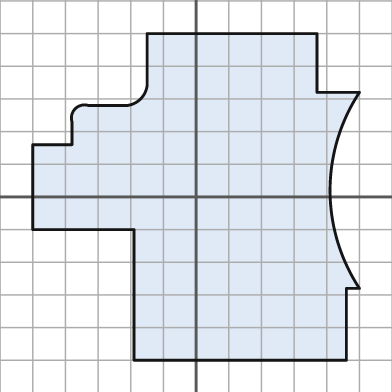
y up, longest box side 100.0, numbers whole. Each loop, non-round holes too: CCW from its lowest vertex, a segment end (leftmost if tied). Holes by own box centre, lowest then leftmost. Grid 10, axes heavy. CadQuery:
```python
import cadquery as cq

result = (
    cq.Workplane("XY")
    .moveTo(-19.0, -50.0)
    .lineTo(46.0, -50.0)
    .lineTo(46.0, -28.0)
    .lineTo(50.0, -28.0)
    .threePointArc((41.0, 2.0), (50.0, 32.0))
    .lineTo(37.0, 32.0)
    .lineTo(37.0, 50.0)
    .lineTo(-15.0, 50.0)
    .lineTo(-15.0, 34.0)
    .threePointArc((-17.0, 30.0), (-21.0, 28.0))
    .lineTo(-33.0, 28.0)
    .threePointArc((-37.0, 27.0), (-38.0, 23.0))
    .lineTo(-38.0, 16.0)
    .lineTo(-50.0, 16.0)
    .lineTo(-50.0, -10.0)
    .lineTo(-19.0, -10.0)
    .close()
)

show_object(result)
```